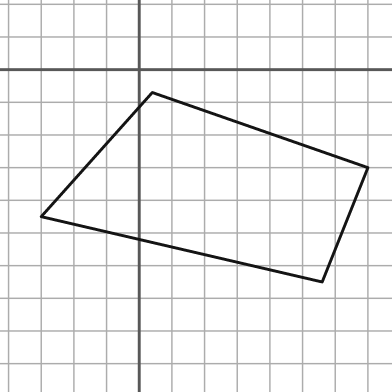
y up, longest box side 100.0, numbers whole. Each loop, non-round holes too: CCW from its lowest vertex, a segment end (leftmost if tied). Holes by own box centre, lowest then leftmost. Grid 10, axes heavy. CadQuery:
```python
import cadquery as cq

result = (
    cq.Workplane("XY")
    .moveTo(56.0, -65.0)
    .lineTo(70.0, -30.0)
    .lineTo(4.0, -7.0)
    .lineTo(-30.0, -45.0)
    .close()
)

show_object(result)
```